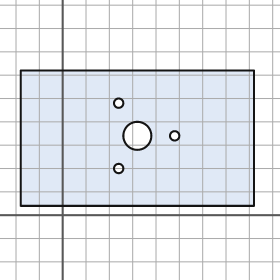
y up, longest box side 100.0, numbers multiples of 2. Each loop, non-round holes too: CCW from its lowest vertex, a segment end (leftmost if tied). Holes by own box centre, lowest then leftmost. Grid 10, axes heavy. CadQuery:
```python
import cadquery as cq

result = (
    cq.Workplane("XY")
    .moveTo(-18.0, 4.0)
    .lineTo(82.0, 4.0)
    .lineTo(82.0, 62.0)
    .lineTo(-18.0, 62.0)
    .close()
    .moveTo(24.0, 20.0)
    .circle(2.0)
    .moveTo(32.0, 34.0)
    .circle(6.0)
    .moveTo(48.0, 34.0)
    .circle(2.0)
    .moveTo(24.0, 48.0)
    .circle(2.0)
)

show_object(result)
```